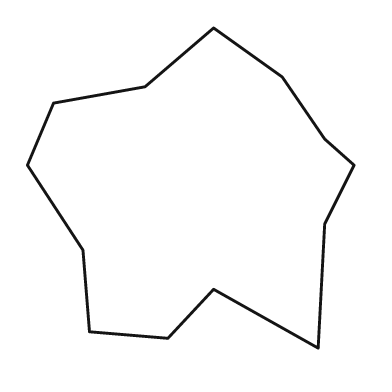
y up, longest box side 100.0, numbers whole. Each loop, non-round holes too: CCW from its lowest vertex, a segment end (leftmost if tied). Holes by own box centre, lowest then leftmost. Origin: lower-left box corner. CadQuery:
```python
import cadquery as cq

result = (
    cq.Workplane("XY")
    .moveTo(89.0, 0.0)
    .lineTo(91.0, 38.0)
    .lineTo(100.0, 56.0)
    .lineTo(91.0, 64.0)
    .lineTo(78.0, 83.0)
    .lineTo(57.0, 98.0)
    .lineTo(36.0, 80.0)
    .lineTo(8.0, 75.0)
    .lineTo(0.0, 56.0)
    .lineTo(17.0, 30.0)
    .lineTo(19.0, 5.0)
    .lineTo(43.0, 3.0)
    .lineTo(57.0, 18.0)
    .close()
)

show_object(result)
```